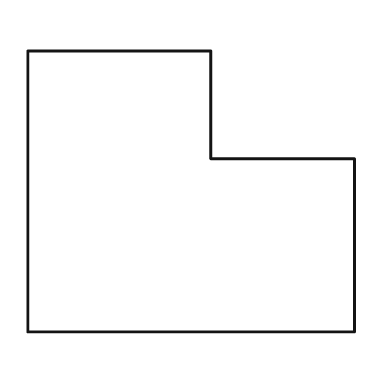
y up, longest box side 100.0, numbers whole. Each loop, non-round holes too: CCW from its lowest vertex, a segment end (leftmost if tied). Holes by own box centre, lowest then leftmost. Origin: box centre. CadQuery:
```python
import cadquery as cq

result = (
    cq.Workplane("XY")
    .moveTo(-50.0, -43.0)
    .lineTo(50.0, -43.0)
    .lineTo(50.0, 10.0)
    .lineTo(6.0, 10.0)
    .lineTo(6.0, 43.0)
    .lineTo(-50.0, 43.0)
    .close()
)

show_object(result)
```